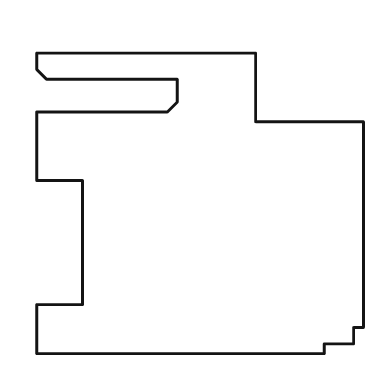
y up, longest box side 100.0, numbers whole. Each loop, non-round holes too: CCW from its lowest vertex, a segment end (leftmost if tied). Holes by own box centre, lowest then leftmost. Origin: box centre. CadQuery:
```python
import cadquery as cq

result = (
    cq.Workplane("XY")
    .moveTo(-50.0, -46.0)
    .lineTo(38.0, -46.0)
    .lineTo(38.0, -43.0)
    .lineTo(47.0, -43.0)
    .lineTo(47.0, -38.0)
    .lineTo(50.0, -38.0)
    .lineTo(50.0, 25.0)
    .lineTo(17.0, 25.0)
    .lineTo(17.0, 46.0)
    .lineTo(-50.0, 46.0)
    .lineTo(-50.0, 41.0)
    .lineTo(-47.0, 38.0)
    .lineTo(-7.0, 38.0)
    .lineTo(-7.0, 31.0)
    .lineTo(-10.0, 28.0)
    .lineTo(-50.0, 28.0)
    .lineTo(-50.0, 7.0)
    .lineTo(-36.0, 7.0)
    .lineTo(-36.0, -31.0)
    .lineTo(-50.0, -31.0)
    .close()
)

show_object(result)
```